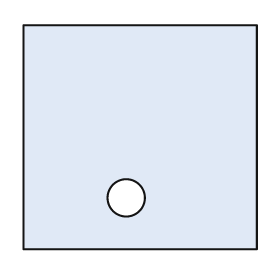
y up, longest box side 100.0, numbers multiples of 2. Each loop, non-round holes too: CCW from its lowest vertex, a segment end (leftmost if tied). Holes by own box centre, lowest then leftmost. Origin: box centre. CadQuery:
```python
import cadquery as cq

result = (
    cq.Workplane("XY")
    .moveTo(-50.0, -48.0)
    .lineTo(50.0, -48.0)
    .lineTo(50.0, 48.0)
    .lineTo(-50.0, 48.0)
    .close()
    .moveTo(-6.0, -26.0)
    .circle(8.0)
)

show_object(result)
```